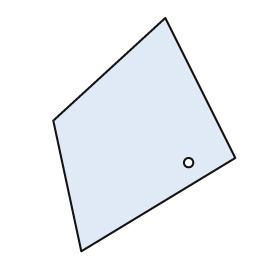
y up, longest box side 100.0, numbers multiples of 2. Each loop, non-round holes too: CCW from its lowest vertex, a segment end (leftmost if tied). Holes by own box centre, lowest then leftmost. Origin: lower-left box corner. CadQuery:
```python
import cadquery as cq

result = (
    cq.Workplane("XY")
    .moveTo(12.0, 0.0)
    .lineTo(78.0, 40.0)
    .lineTo(48.0, 100.0)
    .lineTo(0.0, 56.0)
    .close()
    .moveTo(58.0, 38.0)
    .circle(2.0)
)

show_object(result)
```